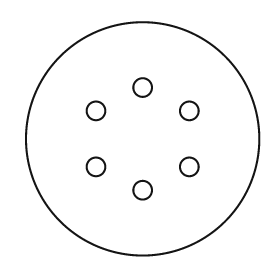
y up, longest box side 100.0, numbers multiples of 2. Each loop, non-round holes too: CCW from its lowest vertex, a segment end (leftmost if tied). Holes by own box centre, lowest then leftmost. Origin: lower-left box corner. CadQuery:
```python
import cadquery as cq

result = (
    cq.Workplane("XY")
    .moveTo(50.0, 50.0)
    .circle(50.0)
    .moveTo(50.0, 28.0)
    .circle(4.0)
    .moveTo(30.0, 38.0)
    .circle(4.0)
    .moveTo(70.0, 38.0)
    .circle(4.0)
    .moveTo(30.0, 62.0)
    .circle(4.0)
    .moveTo(70.0, 62.0)
    .circle(4.0)
    .moveTo(50.0, 72.0)
    .circle(4.0)
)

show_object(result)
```